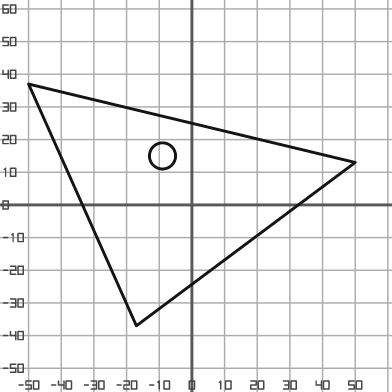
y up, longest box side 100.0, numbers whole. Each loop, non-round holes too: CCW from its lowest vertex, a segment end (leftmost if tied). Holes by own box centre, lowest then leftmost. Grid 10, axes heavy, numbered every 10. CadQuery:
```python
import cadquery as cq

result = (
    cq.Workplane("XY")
    .moveTo(-17.0, -37.0)
    .lineTo(50.0, 13.0)
    .lineTo(-50.0, 37.0)
    .close()
    .moveTo(-9.0, 15.0)
    .circle(4.0)
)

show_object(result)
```